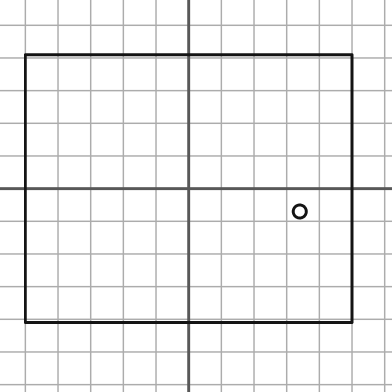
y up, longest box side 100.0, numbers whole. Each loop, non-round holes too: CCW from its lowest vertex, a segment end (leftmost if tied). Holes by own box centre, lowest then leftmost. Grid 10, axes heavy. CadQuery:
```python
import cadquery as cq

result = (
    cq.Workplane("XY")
    .moveTo(-50.0, -41.0)
    .lineTo(50.0, -41.0)
    .lineTo(50.0, 41.0)
    .lineTo(-50.0, 41.0)
    .close()
    .moveTo(34.0, -7.0)
    .circle(2.0)
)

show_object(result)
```